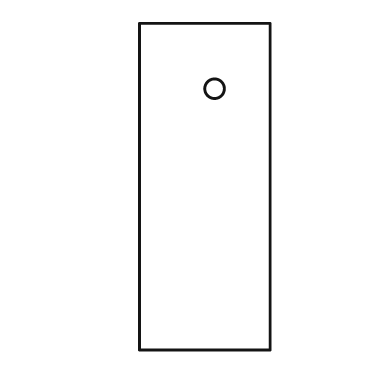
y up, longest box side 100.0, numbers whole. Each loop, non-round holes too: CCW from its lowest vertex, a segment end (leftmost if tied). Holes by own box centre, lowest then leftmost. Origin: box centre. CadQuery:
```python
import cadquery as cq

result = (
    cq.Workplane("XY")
    .moveTo(-20.0, -50.0)
    .lineTo(20.0, -50.0)
    .lineTo(20.0, 50.0)
    .lineTo(-20.0, 50.0)
    .close()
    .moveTo(3.0, 30.0)
    .circle(3.0)
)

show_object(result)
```